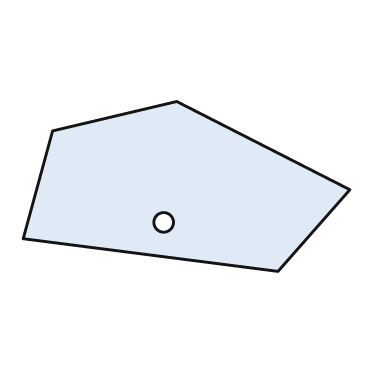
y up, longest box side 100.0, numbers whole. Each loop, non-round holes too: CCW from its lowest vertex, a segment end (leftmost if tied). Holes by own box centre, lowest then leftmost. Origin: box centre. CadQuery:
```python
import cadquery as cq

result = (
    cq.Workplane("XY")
    .moveTo(28.0, -26.0)
    .lineTo(50.0, -1.0)
    .lineTo(-3.0, 26.0)
    .lineTo(-41.0, 17.0)
    .lineTo(-50.0, -16.0)
    .close()
    .moveTo(-7.0, -11.0)
    .circle(3.0)
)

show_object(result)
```